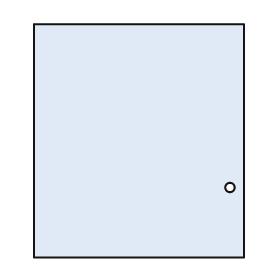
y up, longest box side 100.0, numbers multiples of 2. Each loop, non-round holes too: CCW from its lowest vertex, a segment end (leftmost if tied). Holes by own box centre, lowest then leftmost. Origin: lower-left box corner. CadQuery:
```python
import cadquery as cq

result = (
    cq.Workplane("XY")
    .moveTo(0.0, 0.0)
    .lineTo(90.0, 0.0)
    .lineTo(90.0, 100.0)
    .lineTo(0.0, 100.0)
    .close()
    .moveTo(84.0, 30.0)
    .circle(2.0)
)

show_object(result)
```